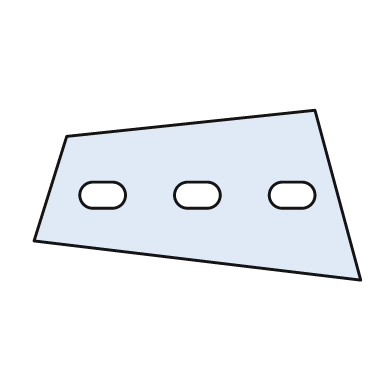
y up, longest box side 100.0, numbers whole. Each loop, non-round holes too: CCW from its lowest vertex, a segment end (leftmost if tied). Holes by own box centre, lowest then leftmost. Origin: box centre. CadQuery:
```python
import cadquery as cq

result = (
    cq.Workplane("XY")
    .moveTo(50.0, -26.0)
    .lineTo(36.0, 26.0)
    .lineTo(-40.0, 18.0)
    .lineTo(-50.0, -14.0)
    .close()
    .moveTo(-32.0, -4.0)
    .lineTo(-26.0, -4.0)
    .threePointArc((-22.0, 0.0), (-26.0, 4.0))
    .lineTo(-32.0, 4.0)
    .threePointArc((-36.0, 0.0), (-32.0, -4.0))
    .close()
    .moveTo(-3.0, -4.0)
    .lineTo(3.0, -4.0)
    .threePointArc((7.0, 0.0), (3.0, 4.0))
    .lineTo(-3.0, 4.0)
    .threePointArc((-7.0, 0.0), (-3.0, -4.0))
    .close()
    .moveTo(26.0, -4.0)
    .lineTo(32.0, -4.0)
    .threePointArc((36.0, 0.0), (32.0, 4.0))
    .lineTo(26.0, 4.0)
    .threePointArc((22.0, 0.0), (26.0, -4.0))
    .close()
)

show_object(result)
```